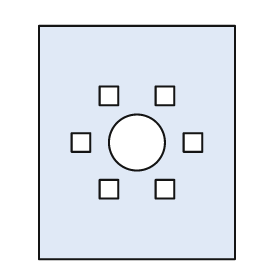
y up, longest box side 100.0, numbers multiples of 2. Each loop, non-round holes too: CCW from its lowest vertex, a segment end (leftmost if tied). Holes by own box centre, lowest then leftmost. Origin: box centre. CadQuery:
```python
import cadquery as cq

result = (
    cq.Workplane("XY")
    .moveTo(-42.0, -50.0)
    .lineTo(42.0, -50.0)
    .lineTo(42.0, 50.0)
    .lineTo(-42.0, 50.0)
    .close()
    .moveTo(-16.0, -24.0)
    .lineTo(-8.0, -24.0)
    .lineTo(-8.0, -16.0)
    .lineTo(-16.0, -16.0)
    .close()
    .moveTo(8.0, -24.0)
    .lineTo(16.0, -24.0)
    .lineTo(16.0, -16.0)
    .lineTo(8.0, -16.0)
    .close()
    .moveTo(-28.0, -4.0)
    .lineTo(-20.0, -4.0)
    .lineTo(-20.0, 4.0)
    .lineTo(-28.0, 4.0)
    .close()
    .moveTo(0.0, 0.0)
    .circle(12.0)
    .moveTo(20.0, -4.0)
    .lineTo(28.0, -4.0)
    .lineTo(28.0, 4.0)
    .lineTo(20.0, 4.0)
    .close()
    .moveTo(-16.0, 16.0)
    .lineTo(-8.0, 16.0)
    .lineTo(-8.0, 24.0)
    .lineTo(-16.0, 24.0)
    .close()
    .moveTo(8.0, 16.0)
    .lineTo(16.0, 16.0)
    .lineTo(16.0, 24.0)
    .lineTo(8.0, 24.0)
    .close()
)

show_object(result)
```